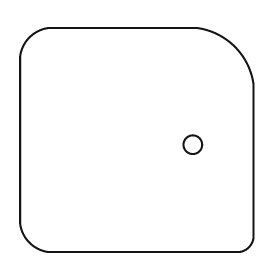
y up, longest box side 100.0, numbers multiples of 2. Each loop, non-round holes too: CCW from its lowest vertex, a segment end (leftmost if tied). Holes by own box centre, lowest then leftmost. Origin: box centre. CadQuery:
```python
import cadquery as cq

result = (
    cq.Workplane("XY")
    .moveTo(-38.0, -48.0)
    .lineTo(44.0, -48.0)
    .threePointArc((48.0, -46.0), (50.0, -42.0))
    .lineTo(50.0, 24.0)
    .threePointArc((42.0, 40.0), (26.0, 48.0))
    .lineTo(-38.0, 48.0)
    .threePointArc((-46.0, 44.0), (-50.0, 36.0))
    .lineTo(-50.0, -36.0)
    .threePointArc((-46.0, -44.0), (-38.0, -48.0))
    .close()
    .moveTo(24.0, -2.0)
    .circle(4.0)
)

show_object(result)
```